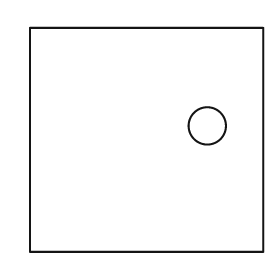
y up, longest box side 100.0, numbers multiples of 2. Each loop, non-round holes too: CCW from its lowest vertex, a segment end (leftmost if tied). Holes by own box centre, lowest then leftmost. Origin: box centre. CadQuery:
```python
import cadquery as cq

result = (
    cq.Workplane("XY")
    .moveTo(-50.0, -48.0)
    .lineTo(50.0, -48.0)
    .lineTo(50.0, 48.0)
    .lineTo(-50.0, 48.0)
    .close()
    .moveTo(26.0, 6.0)
    .circle(8.0)
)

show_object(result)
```